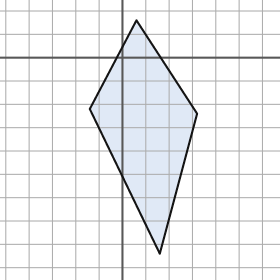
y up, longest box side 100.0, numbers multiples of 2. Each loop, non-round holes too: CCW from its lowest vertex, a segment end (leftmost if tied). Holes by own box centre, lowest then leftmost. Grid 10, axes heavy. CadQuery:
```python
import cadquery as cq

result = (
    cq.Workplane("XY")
    .moveTo(16.0, -84.0)
    .lineTo(32.0, -24.0)
    .lineTo(6.0, 16.0)
    .lineTo(-14.0, -22.0)
    .close()
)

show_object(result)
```